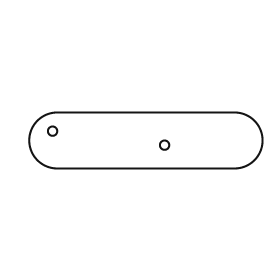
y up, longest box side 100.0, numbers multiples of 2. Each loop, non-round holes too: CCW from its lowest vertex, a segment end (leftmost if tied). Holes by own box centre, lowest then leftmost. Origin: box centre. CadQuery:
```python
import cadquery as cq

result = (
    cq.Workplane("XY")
    .moveTo(-38.0, -12.0)
    .lineTo(38.0, -12.0)
    .threePointArc((50.0, 0.0), (38.0, 12.0))
    .lineTo(-38.0, 12.0)
    .threePointArc((-50.0, 0.0), (-38.0, -12.0))
    .close()
    .moveTo(8.0, -2.0)
    .circle(2.0)
    .moveTo(-40.0, 4.0)
    .circle(2.0)
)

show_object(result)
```